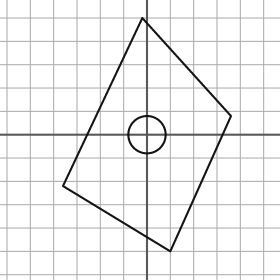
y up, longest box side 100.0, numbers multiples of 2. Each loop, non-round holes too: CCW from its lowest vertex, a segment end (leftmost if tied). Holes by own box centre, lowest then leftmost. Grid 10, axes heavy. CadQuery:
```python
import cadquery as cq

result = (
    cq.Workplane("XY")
    .moveTo(10.0, -50.0)
    .lineTo(36.0, 8.0)
    .lineTo(-2.0, 50.0)
    .lineTo(-36.0, -22.0)
    .close()
    .moveTo(0.0, 0.0)
    .circle(8.0)
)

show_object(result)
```